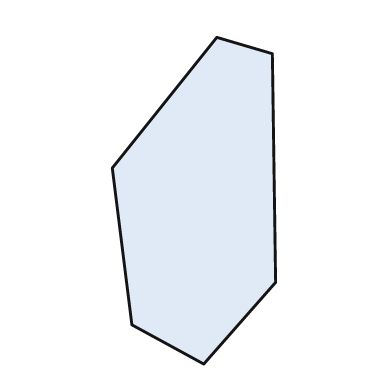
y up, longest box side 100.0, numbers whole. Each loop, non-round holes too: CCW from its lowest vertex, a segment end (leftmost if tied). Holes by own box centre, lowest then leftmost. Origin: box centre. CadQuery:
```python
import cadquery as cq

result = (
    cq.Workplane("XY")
    .moveTo(3.0, -50.0)
    .lineTo(25.0, -25.0)
    .lineTo(24.0, 45.0)
    .lineTo(7.0, 50.0)
    .lineTo(-25.0, 10.0)
    .lineTo(-19.0, -38.0)
    .close()
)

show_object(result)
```